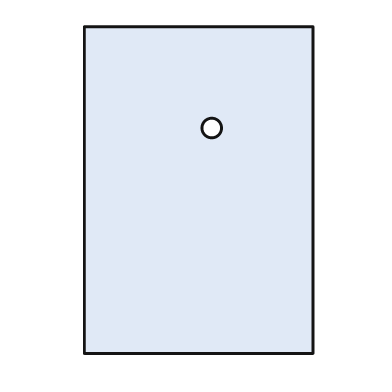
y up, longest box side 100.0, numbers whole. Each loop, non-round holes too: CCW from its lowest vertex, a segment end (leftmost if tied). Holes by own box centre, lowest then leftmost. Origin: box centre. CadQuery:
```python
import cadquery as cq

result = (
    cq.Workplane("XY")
    .moveTo(-35.0, -50.0)
    .lineTo(35.0, -50.0)
    .lineTo(35.0, 50.0)
    .lineTo(-35.0, 50.0)
    .close()
    .moveTo(4.0, 19.0)
    .circle(3.0)
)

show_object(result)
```